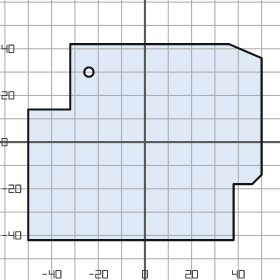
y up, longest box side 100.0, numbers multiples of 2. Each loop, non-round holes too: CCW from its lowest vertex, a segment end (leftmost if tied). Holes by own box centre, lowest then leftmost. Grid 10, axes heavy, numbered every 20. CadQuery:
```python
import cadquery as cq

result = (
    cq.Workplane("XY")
    .moveTo(-50.0, -42.0)
    .lineTo(38.0, -42.0)
    .lineTo(38.0, -18.0)
    .lineTo(46.0, -18.0)
    .lineTo(50.0, -14.0)
    .lineTo(50.0, 36.0)
    .lineTo(36.0, 42.0)
    .lineTo(-32.0, 42.0)
    .lineTo(-32.0, 14.0)
    .lineTo(-50.0, 14.0)
    .close()
    .moveTo(-24.0, 30.0)
    .circle(2.0)
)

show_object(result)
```